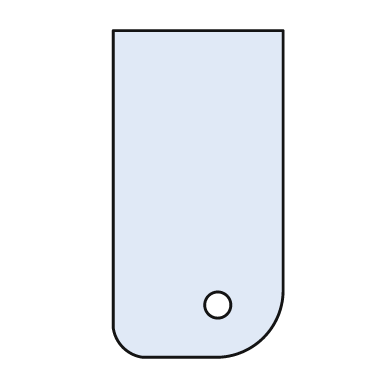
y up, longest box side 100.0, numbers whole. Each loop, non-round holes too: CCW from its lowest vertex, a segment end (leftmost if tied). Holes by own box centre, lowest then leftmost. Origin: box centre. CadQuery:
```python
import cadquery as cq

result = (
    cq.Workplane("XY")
    .moveTo(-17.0, -50.0)
    .lineTo(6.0, -50.0)
    .threePointArc((20.0, -44.0), (26.0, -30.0))
    .lineTo(26.0, 50.0)
    .lineTo(-26.0, 50.0)
    .lineTo(-26.0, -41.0)
    .threePointArc((-23.0, -47.0), (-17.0, -50.0))
    .close()
    .moveTo(6.0, -34.0)
    .circle(4.0)
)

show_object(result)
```